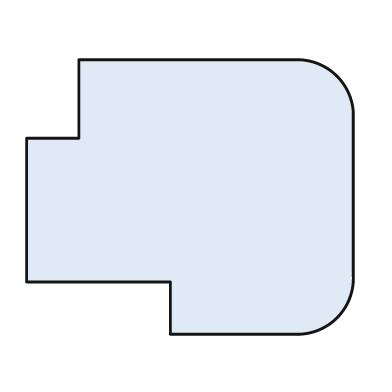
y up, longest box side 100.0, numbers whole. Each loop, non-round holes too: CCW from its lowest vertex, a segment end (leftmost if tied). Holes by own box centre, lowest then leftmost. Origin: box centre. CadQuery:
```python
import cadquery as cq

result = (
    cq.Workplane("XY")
    .moveTo(-6.0, -42.0)
    .lineTo(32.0, -42.0)
    .threePointArc((45.0, -37.0), (50.0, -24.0))
    .lineTo(50.0, 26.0)
    .threePointArc((45.0, 37.0), (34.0, 42.0))
    .lineTo(-34.0, 42.0)
    .lineTo(-34.0, 18.0)
    .lineTo(-50.0, 18.0)
    .lineTo(-50.0, -26.0)
    .lineTo(-6.0, -26.0)
    .close()
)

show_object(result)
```